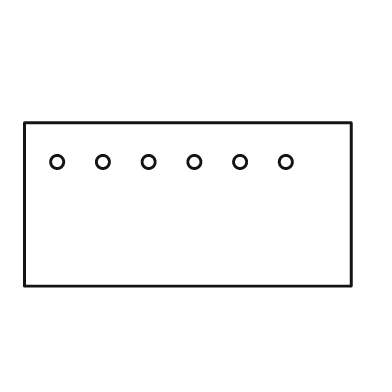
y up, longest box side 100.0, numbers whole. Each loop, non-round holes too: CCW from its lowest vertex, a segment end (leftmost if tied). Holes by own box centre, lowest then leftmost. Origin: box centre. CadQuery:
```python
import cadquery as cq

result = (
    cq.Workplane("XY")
    .moveTo(-50.0, -25.0)
    .lineTo(50.0, -25.0)
    .lineTo(50.0, 25.0)
    .lineTo(-50.0, 25.0)
    .close()
    .moveTo(-40.0, 13.0)
    .circle(2.0)
    .moveTo(-26.0, 13.0)
    .circle(2.0)
    .moveTo(-12.0, 13.0)
    .circle(2.0)
    .moveTo(2.0, 13.0)
    .circle(2.0)
    .moveTo(16.0, 13.0)
    .circle(2.0)
    .moveTo(30.0, 13.0)
    .circle(2.0)
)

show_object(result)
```